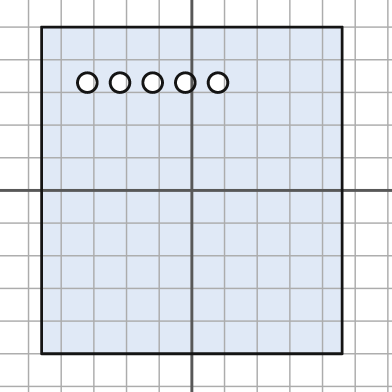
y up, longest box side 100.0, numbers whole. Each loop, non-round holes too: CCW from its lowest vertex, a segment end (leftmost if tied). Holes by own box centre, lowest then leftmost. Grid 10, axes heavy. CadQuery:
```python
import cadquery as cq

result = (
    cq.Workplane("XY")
    .moveTo(-46.0, -50.0)
    .lineTo(46.0, -50.0)
    .lineTo(46.0, 50.0)
    .lineTo(-46.0, 50.0)
    .close()
    .moveTo(-32.0, 33.0)
    .circle(3.0)
    .moveTo(-22.0, 33.0)
    .circle(3.0)
    .moveTo(-12.0, 33.0)
    .circle(3.0)
    .moveTo(-2.0, 33.0)
    .circle(3.0)
    .moveTo(8.0, 33.0)
    .circle(3.0)
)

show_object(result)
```